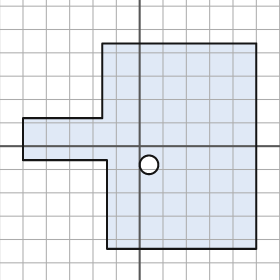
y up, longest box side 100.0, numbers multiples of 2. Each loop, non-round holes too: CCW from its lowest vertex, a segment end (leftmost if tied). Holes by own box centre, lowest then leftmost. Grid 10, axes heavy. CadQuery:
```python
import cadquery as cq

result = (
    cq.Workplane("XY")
    .moveTo(-14.0, -44.0)
    .lineTo(50.0, -44.0)
    .lineTo(50.0, 44.0)
    .lineTo(-16.0, 44.0)
    .lineTo(-16.0, 12.0)
    .lineTo(-50.0, 12.0)
    .lineTo(-50.0, -6.0)
    .lineTo(-14.0, -6.0)
    .close()
    .moveTo(4.0, -8.0)
    .circle(4.0)
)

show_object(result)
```